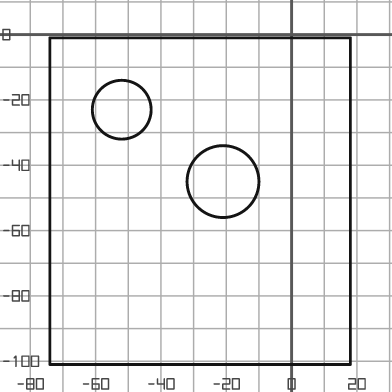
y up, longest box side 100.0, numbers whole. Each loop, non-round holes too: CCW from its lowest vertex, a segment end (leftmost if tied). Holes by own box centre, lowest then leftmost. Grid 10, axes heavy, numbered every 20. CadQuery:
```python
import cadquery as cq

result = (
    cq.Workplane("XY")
    .moveTo(-74.0, -101.0)
    .lineTo(18.0, -101.0)
    .lineTo(18.0, -1.0)
    .lineTo(-74.0, -1.0)
    .close()
    .moveTo(-21.0, -45.0)
    .circle(11.0)
    .moveTo(-52.0, -23.0)
    .circle(9.0)
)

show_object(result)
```